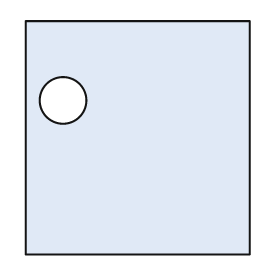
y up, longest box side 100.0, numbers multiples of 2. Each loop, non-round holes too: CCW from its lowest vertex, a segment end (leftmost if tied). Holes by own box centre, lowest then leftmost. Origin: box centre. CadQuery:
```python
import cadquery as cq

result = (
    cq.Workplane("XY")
    .moveTo(-48.0, -50.0)
    .lineTo(48.0, -50.0)
    .lineTo(48.0, 50.0)
    .lineTo(-48.0, 50.0)
    .close()
    .moveTo(-32.0, 16.0)
    .circle(10.0)
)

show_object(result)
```